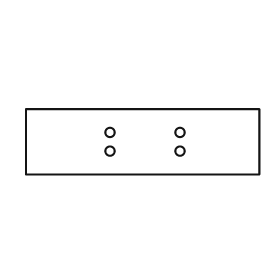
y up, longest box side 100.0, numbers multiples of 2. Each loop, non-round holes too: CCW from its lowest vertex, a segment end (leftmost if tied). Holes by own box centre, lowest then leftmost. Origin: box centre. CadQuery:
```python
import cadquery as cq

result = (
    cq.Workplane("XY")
    .moveTo(-50.0, -14.0)
    .lineTo(50.0, -14.0)
    .lineTo(50.0, 14.0)
    .lineTo(-50.0, 14.0)
    .close()
    .moveTo(-14.0, -4.0)
    .circle(2.0)
    .moveTo(16.0, -4.0)
    .circle(2.0)
    .moveTo(-14.0, 4.0)
    .circle(2.0)
    .moveTo(16.0, 4.0)
    .circle(2.0)
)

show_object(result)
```